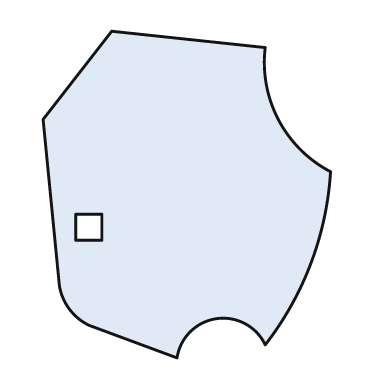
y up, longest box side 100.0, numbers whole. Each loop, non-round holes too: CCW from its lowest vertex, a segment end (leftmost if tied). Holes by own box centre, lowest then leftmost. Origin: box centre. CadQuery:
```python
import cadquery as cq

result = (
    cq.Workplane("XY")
    .moveTo(-3.0, -50.0)
    .threePointArc((9.0, -38.0), (24.0, -46.0))
    .threePointArc((38.0, -21.0), (44.0, 7.0))
    .threePointArc((28.0, 23.0), (24.0, 45.0))
    .lineTo(-23.0, 50.0)
    .lineTo(-44.0, 23.0)
    .lineTo(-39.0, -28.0)
    .threePointArc((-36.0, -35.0), (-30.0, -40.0))
    .close()
    .moveTo(-34.0, -14.0)
    .lineTo(-26.0, -14.0)
    .lineTo(-26.0, -6.0)
    .lineTo(-34.0, -6.0)
    .close()
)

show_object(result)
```